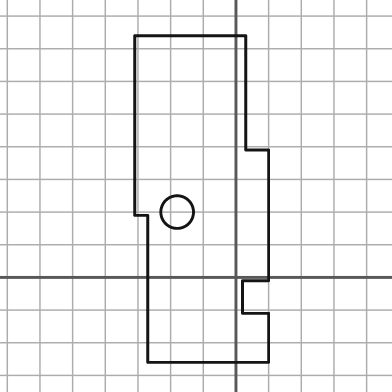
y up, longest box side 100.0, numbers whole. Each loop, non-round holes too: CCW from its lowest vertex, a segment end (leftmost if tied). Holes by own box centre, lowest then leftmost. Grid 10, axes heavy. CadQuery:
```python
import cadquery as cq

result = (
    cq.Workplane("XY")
    .moveTo(-27.0, -26.0)
    .lineTo(10.0, -26.0)
    .lineTo(10.0, -11.0)
    .lineTo(2.0, -11.0)
    .lineTo(2.0, -1.0)
    .lineTo(10.0, -1.0)
    .lineTo(10.0, 39.0)
    .lineTo(3.0, 39.0)
    .lineTo(3.0, 74.0)
    .lineTo(-31.0, 74.0)
    .lineTo(-31.0, 19.0)
    .lineTo(-27.0, 19.0)
    .close()
    .moveTo(-18.0, 20.0)
    .circle(5.0)
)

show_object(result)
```